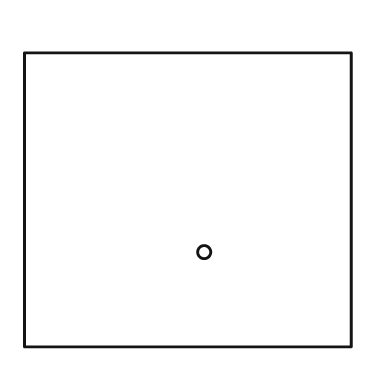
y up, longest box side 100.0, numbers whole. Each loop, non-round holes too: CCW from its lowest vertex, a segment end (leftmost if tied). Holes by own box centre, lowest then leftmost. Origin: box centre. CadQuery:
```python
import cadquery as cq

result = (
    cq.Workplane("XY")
    .moveTo(-50.0, -45.0)
    .lineTo(50.0, -45.0)
    .lineTo(50.0, 45.0)
    .lineTo(-50.0, 45.0)
    .close()
    .moveTo(5.0, -16.0)
    .circle(2.0)
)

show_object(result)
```